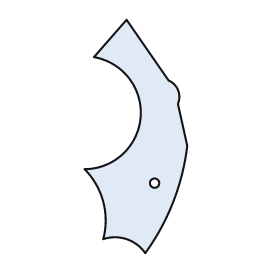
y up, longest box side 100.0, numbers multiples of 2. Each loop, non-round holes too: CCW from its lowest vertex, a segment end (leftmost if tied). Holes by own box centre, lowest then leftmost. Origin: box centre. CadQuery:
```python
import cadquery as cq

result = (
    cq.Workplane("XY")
    .moveTo(4.0, -50.0)
    .threePointArc((16.0, -28.0), (22.0, -4.0))
    .lineTo(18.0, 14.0)
    .threePointArc((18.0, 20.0), (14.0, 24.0))
    .lineTo(-4.0, 50.0)
    .lineTo(-18.0, 34.0)
    .threePointArc((2.0, 8.0), (-22.0, -14.0))
    .threePointArc((-14.0, -28.0), (-14.0, -44.0))
    .threePointArc((-4.0, -44.0), (4.0, -50.0))
    .close()
    .moveTo(8.0, -20.0)
    .circle(2.0)
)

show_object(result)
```